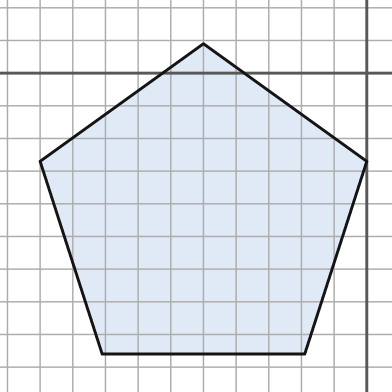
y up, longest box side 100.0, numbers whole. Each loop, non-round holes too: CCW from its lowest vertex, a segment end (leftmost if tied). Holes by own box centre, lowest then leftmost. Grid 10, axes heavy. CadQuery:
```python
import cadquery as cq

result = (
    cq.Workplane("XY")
    .moveTo(-81.0, -86.0)
    .lineTo(-19.0, -86.0)
    .lineTo(0.0, -27.0)
    .lineTo(-50.0, 9.0)
    .lineTo(-100.0, -27.0)
    .close()
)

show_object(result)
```